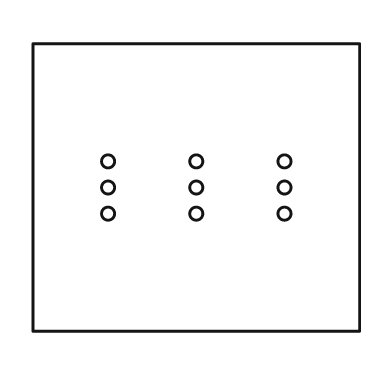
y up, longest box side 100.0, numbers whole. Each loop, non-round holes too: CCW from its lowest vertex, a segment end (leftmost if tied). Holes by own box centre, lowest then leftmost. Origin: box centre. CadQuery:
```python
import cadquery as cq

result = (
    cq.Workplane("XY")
    .moveTo(-50.0, -44.0)
    .lineTo(50.0, -44.0)
    .lineTo(50.0, 44.0)
    .lineTo(-50.0, 44.0)
    .close()
    .moveTo(-27.0, -8.0)
    .circle(2.0)
    .moveTo(0.0, -8.0)
    .circle(2.0)
    .moveTo(27.0, -8.0)
    .circle(2.0)
    .moveTo(-27.0, 0.0)
    .circle(2.0)
    .moveTo(0.0, 0.0)
    .circle(2.0)
    .moveTo(27.0, 0.0)
    .circle(2.0)
    .moveTo(-27.0, 8.0)
    .circle(2.0)
    .moveTo(0.0, 8.0)
    .circle(2.0)
    .moveTo(27.0, 8.0)
    .circle(2.0)
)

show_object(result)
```